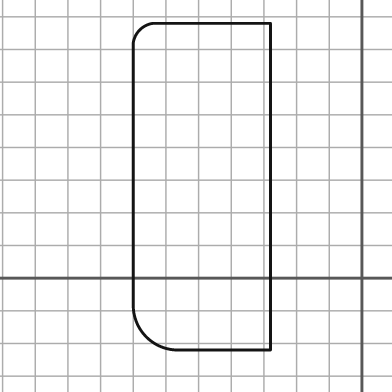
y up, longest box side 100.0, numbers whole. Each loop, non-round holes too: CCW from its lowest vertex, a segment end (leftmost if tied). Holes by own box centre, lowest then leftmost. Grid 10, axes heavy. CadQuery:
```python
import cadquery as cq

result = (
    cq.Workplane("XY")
    .moveTo(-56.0, -22.0)
    .lineTo(-28.0, -22.0)
    .lineTo(-28.0, 78.0)
    .lineTo(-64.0, 78.0)
    .threePointArc((-68.0, 76.0), (-70.0, 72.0))
    .lineTo(-70.0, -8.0)
    .threePointArc((-66.0, -18.0), (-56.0, -22.0))
    .close()
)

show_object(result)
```